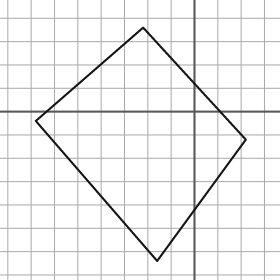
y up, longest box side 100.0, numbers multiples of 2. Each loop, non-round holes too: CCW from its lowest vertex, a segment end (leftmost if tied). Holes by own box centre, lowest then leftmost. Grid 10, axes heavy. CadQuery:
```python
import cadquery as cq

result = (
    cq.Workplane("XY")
    .moveTo(-16.0, -64.0)
    .lineTo(22.0, -12.0)
    .lineTo(-22.0, 36.0)
    .lineTo(-68.0, -4.0)
    .close()
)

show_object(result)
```